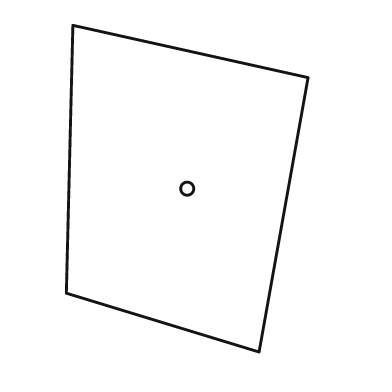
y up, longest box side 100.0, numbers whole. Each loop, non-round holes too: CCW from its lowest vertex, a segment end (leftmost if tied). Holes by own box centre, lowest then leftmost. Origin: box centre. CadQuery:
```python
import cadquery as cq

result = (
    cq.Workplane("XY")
    .moveTo(22.0, -50.0)
    .lineTo(37.0, 34.0)
    .lineTo(-35.0, 50.0)
    .lineTo(-37.0, -32.0)
    .close()
    .moveTo(0.0, 0.0)
    .circle(2.0)
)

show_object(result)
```